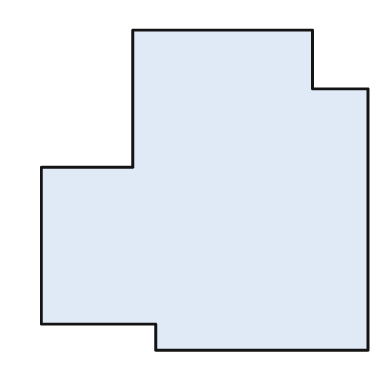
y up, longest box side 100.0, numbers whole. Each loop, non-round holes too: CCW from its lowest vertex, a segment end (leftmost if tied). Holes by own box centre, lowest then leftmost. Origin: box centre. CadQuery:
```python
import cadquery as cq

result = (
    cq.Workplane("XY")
    .moveTo(-15.0, -49.0)
    .lineTo(50.0, -49.0)
    .lineTo(50.0, 31.0)
    .lineTo(33.0, 31.0)
    .lineTo(33.0, 49.0)
    .lineTo(-22.0, 49.0)
    .lineTo(-22.0, 7.0)
    .lineTo(-50.0, 7.0)
    .lineTo(-50.0, -41.0)
    .lineTo(-15.0, -41.0)
    .close()
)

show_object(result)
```